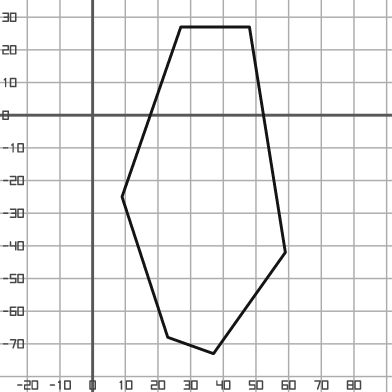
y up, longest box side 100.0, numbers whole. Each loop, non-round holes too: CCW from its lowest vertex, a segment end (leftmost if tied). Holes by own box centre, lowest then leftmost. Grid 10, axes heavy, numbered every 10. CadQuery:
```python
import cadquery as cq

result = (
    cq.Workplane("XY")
    .moveTo(37.0, -73.0)
    .lineTo(59.0, -42.0)
    .lineTo(48.0, 27.0)
    .lineTo(27.0, 27.0)
    .lineTo(9.0, -25.0)
    .lineTo(23.0, -68.0)
    .close()
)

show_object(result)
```